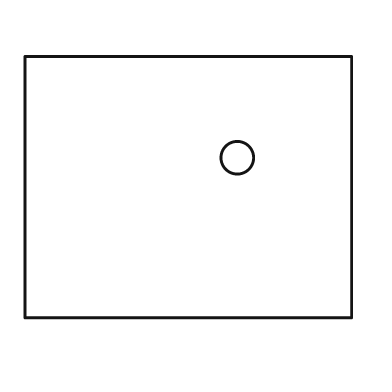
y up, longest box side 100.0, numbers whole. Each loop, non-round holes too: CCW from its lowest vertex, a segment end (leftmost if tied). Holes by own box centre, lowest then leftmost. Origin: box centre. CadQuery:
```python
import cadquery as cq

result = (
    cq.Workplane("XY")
    .moveTo(-50.0, -40.0)
    .lineTo(50.0, -40.0)
    .lineTo(50.0, 40.0)
    .lineTo(-50.0, 40.0)
    .close()
    .moveTo(15.0, 9.0)
    .circle(5.0)
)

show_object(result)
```